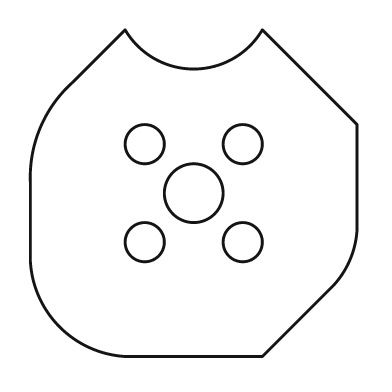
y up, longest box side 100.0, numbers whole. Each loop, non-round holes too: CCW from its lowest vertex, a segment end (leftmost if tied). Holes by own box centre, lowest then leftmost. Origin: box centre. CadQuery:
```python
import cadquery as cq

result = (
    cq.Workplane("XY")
    .moveTo(-21.0, -50.0)
    .lineTo(21.0, -50.0)
    .lineTo(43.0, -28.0)
    .threePointArc((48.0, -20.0), (50.0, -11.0))
    .lineTo(50.0, 21.0)
    .lineTo(21.0, 50.0)
    .threePointArc((0.0, 38.0), (-21.0, 50.0))
    .lineTo(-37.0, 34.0)
    .threePointArc((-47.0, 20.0), (-50.0, 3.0))
    .lineTo(-50.0, -21.0)
    .threePointArc((-41.0, -41.0), (-21.0, -50.0))
    .close()
    .moveTo(-15.0, -15.0)
    .circle(6.0)
    .moveTo(15.0, -15.0)
    .circle(6.0)
    .moveTo(0.0, 0.0)
    .circle(9.0)
    .moveTo(-15.0, 15.0)
    .circle(6.0)
    .moveTo(15.0, 15.0)
    .circle(6.0)
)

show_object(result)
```